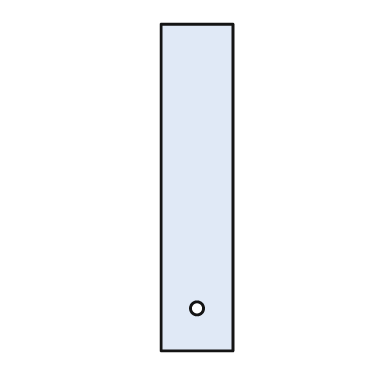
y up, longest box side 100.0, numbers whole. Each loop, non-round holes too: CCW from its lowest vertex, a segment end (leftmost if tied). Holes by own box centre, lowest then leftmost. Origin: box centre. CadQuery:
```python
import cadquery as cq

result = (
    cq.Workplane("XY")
    .moveTo(-11.0, -50.0)
    .lineTo(11.0, -50.0)
    .lineTo(11.0, 50.0)
    .lineTo(-11.0, 50.0)
    .close()
    .moveTo(0.0, -37.0)
    .circle(2.0)
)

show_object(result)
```